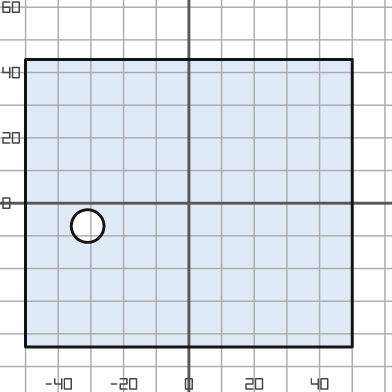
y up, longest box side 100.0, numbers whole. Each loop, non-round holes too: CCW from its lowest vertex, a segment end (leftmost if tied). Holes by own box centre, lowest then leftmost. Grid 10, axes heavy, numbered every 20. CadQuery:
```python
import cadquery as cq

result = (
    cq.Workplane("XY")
    .moveTo(-50.0, -44.0)
    .lineTo(50.0, -44.0)
    .lineTo(50.0, 44.0)
    .lineTo(-50.0, 44.0)
    .close()
    .moveTo(-31.0, -7.0)
    .circle(5.0)
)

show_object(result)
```